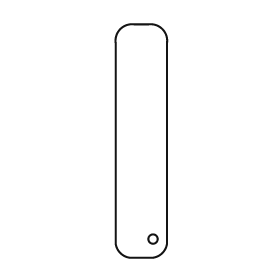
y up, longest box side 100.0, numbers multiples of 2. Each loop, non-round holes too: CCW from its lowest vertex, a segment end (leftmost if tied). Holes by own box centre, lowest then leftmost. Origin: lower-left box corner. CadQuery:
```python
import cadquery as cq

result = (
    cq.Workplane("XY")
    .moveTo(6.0, 0.0)
    .lineTo(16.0, 0.0)
    .threePointArc((20.0, 2.0), (22.0, 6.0))
    .lineTo(22.0, 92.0)
    .threePointArc((20.0, 98.0), (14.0, 100.0))
    .lineTo(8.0, 100.0)
    .threePointArc((2.0, 98.0), (0.0, 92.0))
    .lineTo(0.0, 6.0)
    .threePointArc((2.0, 2.0), (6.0, 0.0))
    .close()
    .moveTo(16.0, 8.0)
    .circle(2.0)
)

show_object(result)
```